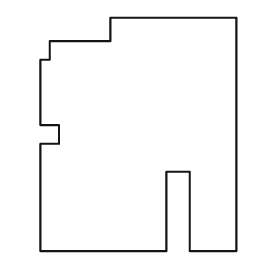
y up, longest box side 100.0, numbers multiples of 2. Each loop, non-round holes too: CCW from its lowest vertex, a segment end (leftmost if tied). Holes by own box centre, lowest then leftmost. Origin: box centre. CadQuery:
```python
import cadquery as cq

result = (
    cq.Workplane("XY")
    .moveTo(-42.0, -50.0)
    .lineTo(12.0, -50.0)
    .lineTo(12.0, -16.0)
    .lineTo(22.0, -16.0)
    .lineTo(22.0, -50.0)
    .lineTo(42.0, -50.0)
    .lineTo(42.0, 50.0)
    .lineTo(-12.0, 50.0)
    .lineTo(-12.0, 40.0)
    .lineTo(-38.0, 40.0)
    .lineTo(-38.0, 32.0)
    .lineTo(-42.0, 32.0)
    .lineTo(-42.0, 4.0)
    .lineTo(-34.0, 4.0)
    .lineTo(-34.0, -4.0)
    .lineTo(-42.0, -4.0)
    .close()
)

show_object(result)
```